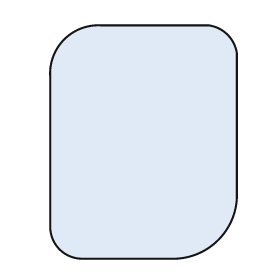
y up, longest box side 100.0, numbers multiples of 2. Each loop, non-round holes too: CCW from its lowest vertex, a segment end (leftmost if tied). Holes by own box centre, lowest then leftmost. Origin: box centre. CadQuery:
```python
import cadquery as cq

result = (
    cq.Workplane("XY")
    .moveTo(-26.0, -50.0)
    .lineTo(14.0, -50.0)
    .threePointArc((32.0, -42.0), (40.0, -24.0))
    .lineTo(40.0, 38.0)
    .threePointArc((36.0, 46.0), (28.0, 50.0))
    .lineTo(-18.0, 50.0)
    .threePointArc((-34.0, 44.0), (-40.0, 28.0))
    .lineTo(-40.0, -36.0)
    .threePointArc((-36.0, -46.0), (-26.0, -50.0))
    .close()
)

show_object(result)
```